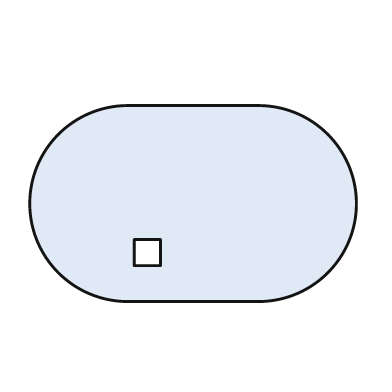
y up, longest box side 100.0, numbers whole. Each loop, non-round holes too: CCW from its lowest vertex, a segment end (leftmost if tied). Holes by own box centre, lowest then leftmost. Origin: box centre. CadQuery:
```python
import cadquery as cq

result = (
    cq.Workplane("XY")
    .moveTo(-20.0, -30.0)
    .lineTo(20.0, -30.0)
    .threePointArc((50.0, 0.0), (20.0, 30.0))
    .lineTo(-20.0, 30.0)
    .threePointArc((-50.0, 0.0), (-20.0, -30.0))
    .close()
    .moveTo(-18.0, -19.0)
    .lineTo(-10.0, -19.0)
    .lineTo(-10.0, -11.0)
    .lineTo(-18.0, -11.0)
    .close()
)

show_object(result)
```